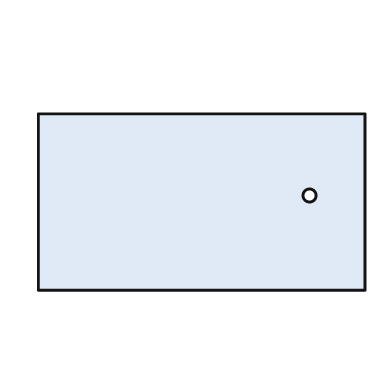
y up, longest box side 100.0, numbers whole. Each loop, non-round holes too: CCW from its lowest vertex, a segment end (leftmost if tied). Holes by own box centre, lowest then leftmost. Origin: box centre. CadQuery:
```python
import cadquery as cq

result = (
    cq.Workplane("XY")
    .moveTo(-50.0, -27.0)
    .lineTo(50.0, -27.0)
    .lineTo(50.0, 27.0)
    .lineTo(-50.0, 27.0)
    .close()
    .moveTo(33.0, 2.0)
    .circle(2.0)
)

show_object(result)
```